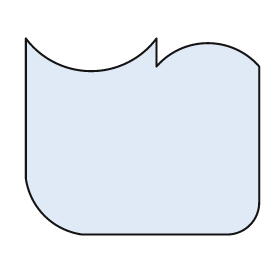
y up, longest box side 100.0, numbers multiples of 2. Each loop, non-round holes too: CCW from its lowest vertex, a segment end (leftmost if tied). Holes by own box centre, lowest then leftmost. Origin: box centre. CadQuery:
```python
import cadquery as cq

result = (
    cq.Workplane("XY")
    .moveTo(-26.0, -42.0)
    .lineTo(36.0, -42.0)
    .threePointArc((46.0, -38.0), (50.0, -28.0))
    .lineTo(50.0, 30.0)
    .threePointArc((28.0, 40.0), (6.0, 30.0))
    .lineTo(6.0, 42.0)
    .threePointArc((-22.0, 28.0), (-50.0, 42.0))
    .lineTo(-50.0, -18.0)
    .threePointArc((-42.0, -34.0), (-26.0, -42.0))
    .close()
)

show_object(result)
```